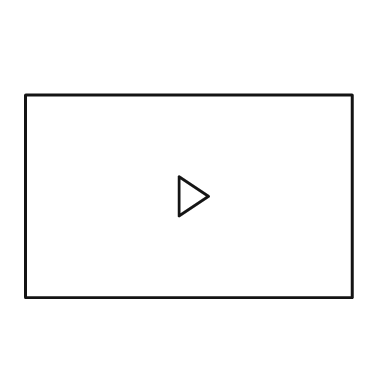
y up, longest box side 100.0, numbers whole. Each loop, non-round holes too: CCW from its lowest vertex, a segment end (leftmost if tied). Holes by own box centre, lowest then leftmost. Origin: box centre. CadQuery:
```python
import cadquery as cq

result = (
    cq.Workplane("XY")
    .moveTo(-50.0, -31.0)
    .lineTo(50.0, -31.0)
    .lineTo(50.0, 31.0)
    .lineTo(-50.0, 31.0)
    .close()
    .moveTo(-3.0, -6.0)
    .lineTo(6.0, 0.0)
    .lineTo(-3.0, 6.0)
    .close()
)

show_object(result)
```